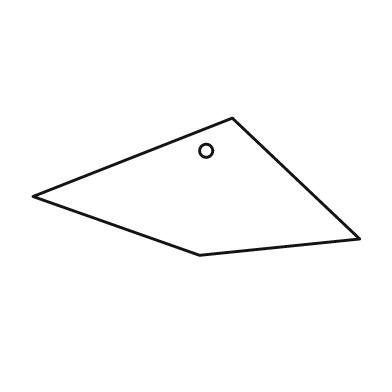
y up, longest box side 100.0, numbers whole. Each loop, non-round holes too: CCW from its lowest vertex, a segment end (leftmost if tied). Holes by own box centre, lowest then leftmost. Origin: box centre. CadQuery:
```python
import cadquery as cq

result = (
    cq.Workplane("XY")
    .moveTo(1.0, -21.0)
    .lineTo(50.0, -16.0)
    .lineTo(11.0, 21.0)
    .lineTo(-50.0, -3.0)
    .close()
    .moveTo(3.0, 11.0)
    .circle(2.0)
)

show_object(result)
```